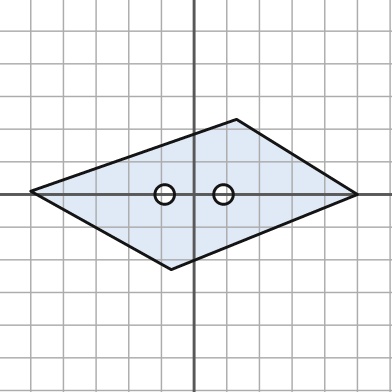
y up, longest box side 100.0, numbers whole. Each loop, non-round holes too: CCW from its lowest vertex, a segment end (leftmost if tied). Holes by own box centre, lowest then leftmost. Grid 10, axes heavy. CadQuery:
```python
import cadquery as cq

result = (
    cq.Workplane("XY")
    .moveTo(-7.0, -23.0)
    .lineTo(50.0, 0.0)
    .lineTo(13.0, 23.0)
    .lineTo(-50.0, 1.0)
    .close()
    .moveTo(-9.0, 0.0)
    .circle(3.0)
    .moveTo(9.0, 0.0)
    .circle(3.0)
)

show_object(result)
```